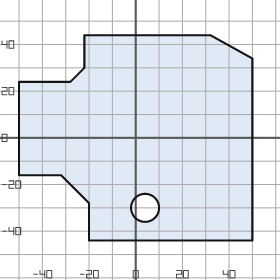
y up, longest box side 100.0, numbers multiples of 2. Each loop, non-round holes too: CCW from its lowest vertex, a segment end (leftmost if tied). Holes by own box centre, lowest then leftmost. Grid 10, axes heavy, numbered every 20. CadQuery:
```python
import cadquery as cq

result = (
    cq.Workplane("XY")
    .moveTo(-20.0, -44.0)
    .lineTo(50.0, -44.0)
    .lineTo(50.0, 34.0)
    .lineTo(32.0, 44.0)
    .lineTo(-22.0, 44.0)
    .lineTo(-22.0, 30.0)
    .lineTo(-28.0, 24.0)
    .lineTo(-50.0, 24.0)
    .lineTo(-50.0, -16.0)
    .lineTo(-32.0, -16.0)
    .lineTo(-20.0, -28.0)
    .close()
    .moveTo(4.0, -30.0)
    .circle(6.0)
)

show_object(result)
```